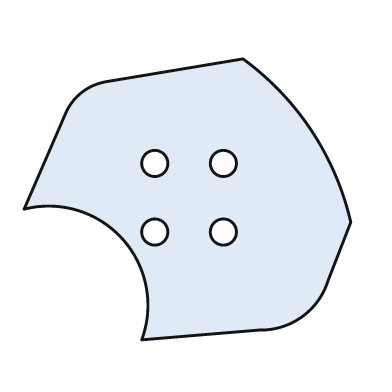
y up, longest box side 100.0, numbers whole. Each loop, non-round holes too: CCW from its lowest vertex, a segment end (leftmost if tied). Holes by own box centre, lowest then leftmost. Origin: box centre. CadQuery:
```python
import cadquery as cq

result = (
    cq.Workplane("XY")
    .moveTo(-14.0, -43.0)
    .lineTo(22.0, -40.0)
    .threePointArc((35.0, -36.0), (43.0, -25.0))
    .lineTo(50.0, -7.0)
    .threePointArc((38.0, 21.0), (17.0, 43.0))
    .lineTo(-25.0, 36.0)
    .threePointArc((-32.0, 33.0), (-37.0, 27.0))
    .lineTo(-50.0, -3.0)
    .threePointArc((-20.0, -12.0), (-14.0, -43.0))
    .close()
    .moveTo(-10.0, -10.0)
    .circle(4.0)
    .moveTo(11.0, -10.0)
    .circle(4.0)
    .moveTo(-10.0, 11.0)
    .circle(4.0)
    .moveTo(11.0, 11.0)
    .circle(4.0)
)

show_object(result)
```